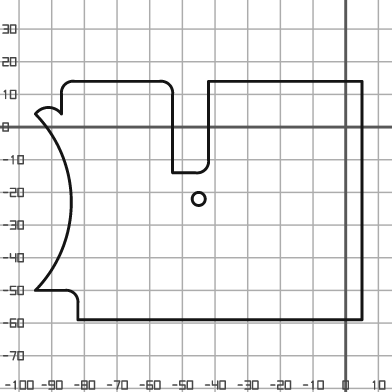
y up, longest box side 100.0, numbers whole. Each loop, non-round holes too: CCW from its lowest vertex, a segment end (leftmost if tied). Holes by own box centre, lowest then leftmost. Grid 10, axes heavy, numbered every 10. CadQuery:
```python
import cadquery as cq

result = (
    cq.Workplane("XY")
    .moveTo(-82.0, -59.0)
    .lineTo(5.0, -59.0)
    .lineTo(5.0, 14.0)
    .lineTo(-42.0, 14.0)
    .lineTo(-42.0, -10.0)
    .threePointArc((-43.0, -13.0), (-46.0, -14.0))
    .lineTo(-53.0, -14.0)
    .lineTo(-53.0, 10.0)
    .threePointArc((-54.0, 13.0), (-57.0, 14.0))
    .lineTo(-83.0, 14.0)
    .threePointArc((-86.0, 13.0), (-87.0, 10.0))
    .lineTo(-87.0, 4.0)
    .threePointArc((-91.0, 6.0), (-95.0, 4.0))
    .threePointArc((-84.0, -23.0), (-95.0, -50.0))
    .lineTo(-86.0, -50.0)
    .threePointArc((-83.0, -51.0), (-82.0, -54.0))
    .close()
    .moveTo(-45.0, -22.0)
    .circle(2.0)
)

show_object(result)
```